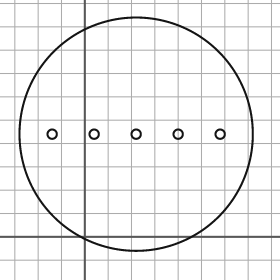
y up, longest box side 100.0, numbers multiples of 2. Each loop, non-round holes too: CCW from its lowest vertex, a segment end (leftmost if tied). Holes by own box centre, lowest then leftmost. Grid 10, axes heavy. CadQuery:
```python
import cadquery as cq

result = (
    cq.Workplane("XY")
    .moveTo(22.0, 44.0)
    .circle(50.0)
    .moveTo(-14.0, 44.0)
    .circle(2.0)
    .moveTo(4.0, 44.0)
    .circle(2.0)
    .moveTo(22.0, 44.0)
    .circle(2.0)
    .moveTo(40.0, 44.0)
    .circle(2.0)
    .moveTo(58.0, 44.0)
    .circle(2.0)
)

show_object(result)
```